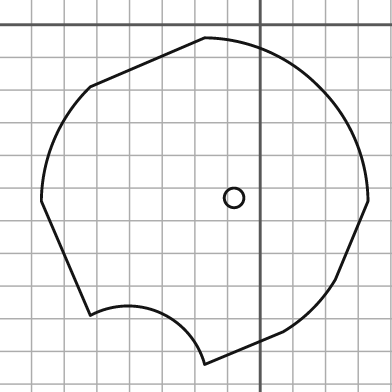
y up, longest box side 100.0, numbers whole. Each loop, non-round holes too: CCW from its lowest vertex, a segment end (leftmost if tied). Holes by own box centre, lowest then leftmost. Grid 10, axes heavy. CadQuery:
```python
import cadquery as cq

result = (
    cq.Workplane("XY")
    .moveTo(-17.0, -104.0)
    .lineTo(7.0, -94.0)
    .threePointArc((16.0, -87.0), (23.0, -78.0))
    .lineTo(33.0, -54.0)
    .threePointArc((29.0, -35.0), (18.0, -19.0))
    .threePointArc((2.0, -8.0), (-17.0, -4.0))
    .lineTo(-52.0, -19.0)
    .threePointArc((-63.0, -35.0), (-67.0, -54.0))
    .lineTo(-52.0, -89.0)
    .threePointArc((-31.0, -88.0), (-17.0, -104.0))
    .close()
    .moveTo(-8.0, -53.0)
    .circle(3.0)
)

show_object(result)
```